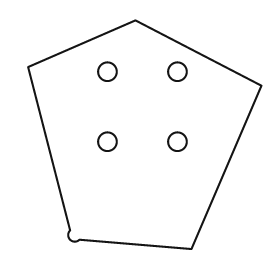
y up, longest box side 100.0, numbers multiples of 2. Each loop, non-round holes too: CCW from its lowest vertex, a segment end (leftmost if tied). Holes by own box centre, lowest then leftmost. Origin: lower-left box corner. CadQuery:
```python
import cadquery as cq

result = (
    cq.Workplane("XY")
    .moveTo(70.0, 0.0)
    .lineTo(100.0, 70.0)
    .lineTo(46.0, 98.0)
    .lineTo(0.0, 78.0)
    .lineTo(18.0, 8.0)
    .threePointArc((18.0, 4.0), (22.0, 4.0))
    .close()
    .moveTo(34.0, 46.0)
    .circle(4.0)
    .moveTo(64.0, 46.0)
    .circle(4.0)
    .moveTo(34.0, 76.0)
    .circle(4.0)
    .moveTo(64.0, 76.0)
    .circle(4.0)
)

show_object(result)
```